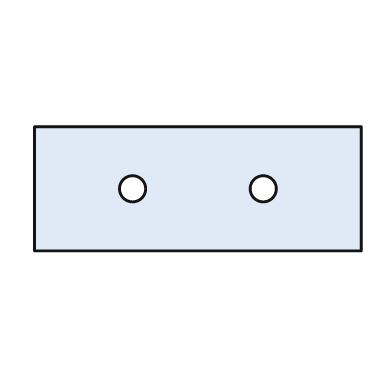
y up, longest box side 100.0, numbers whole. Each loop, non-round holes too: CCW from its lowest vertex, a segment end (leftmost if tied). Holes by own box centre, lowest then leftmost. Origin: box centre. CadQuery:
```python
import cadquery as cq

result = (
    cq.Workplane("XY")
    .moveTo(-50.0, -19.0)
    .lineTo(50.0, -19.0)
    .lineTo(50.0, 19.0)
    .lineTo(-50.0, 19.0)
    .close()
    .moveTo(-20.0, 0.0)
    .circle(4.0)
    .moveTo(20.0, 0.0)
    .circle(4.0)
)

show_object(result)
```